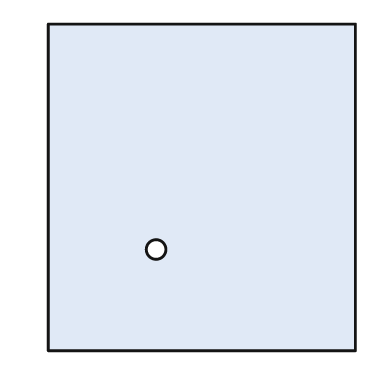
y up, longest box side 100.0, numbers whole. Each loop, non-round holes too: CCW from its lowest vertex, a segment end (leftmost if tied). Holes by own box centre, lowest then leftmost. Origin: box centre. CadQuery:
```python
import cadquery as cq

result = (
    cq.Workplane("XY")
    .moveTo(-47.0, -50.0)
    .lineTo(47.0, -50.0)
    .lineTo(47.0, 50.0)
    .lineTo(-47.0, 50.0)
    .close()
    .moveTo(-14.0, -19.0)
    .circle(3.0)
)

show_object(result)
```